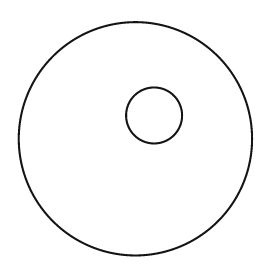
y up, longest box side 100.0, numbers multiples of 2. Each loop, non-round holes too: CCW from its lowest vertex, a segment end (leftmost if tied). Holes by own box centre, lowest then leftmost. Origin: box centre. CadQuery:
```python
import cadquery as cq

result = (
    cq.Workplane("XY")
    .moveTo(0.0, 0.0)
    .circle(50.0)
    .moveTo(8.0, 10.0)
    .circle(12.0)
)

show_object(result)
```